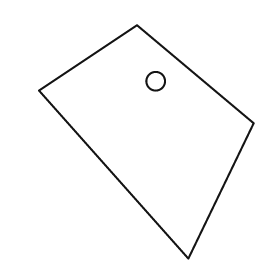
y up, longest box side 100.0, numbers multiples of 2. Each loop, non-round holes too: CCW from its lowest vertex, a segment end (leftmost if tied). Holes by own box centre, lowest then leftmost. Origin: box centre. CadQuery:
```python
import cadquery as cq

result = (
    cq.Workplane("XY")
    .moveTo(18.0, -50.0)
    .lineTo(46.0, 8.0)
    .lineTo(-4.0, 50.0)
    .lineTo(-46.0, 22.0)
    .close()
    .moveTo(4.0, 26.0)
    .circle(4.0)
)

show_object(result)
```